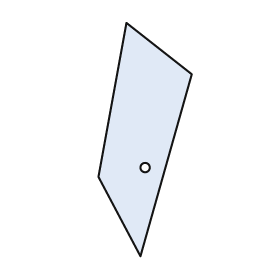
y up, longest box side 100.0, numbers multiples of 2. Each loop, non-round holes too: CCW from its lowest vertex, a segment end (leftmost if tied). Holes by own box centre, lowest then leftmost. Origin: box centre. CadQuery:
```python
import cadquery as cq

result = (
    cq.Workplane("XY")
    .moveTo(-2.0, -50.0)
    .lineTo(20.0, 28.0)
    .lineTo(-8.0, 50.0)
    .lineTo(-20.0, -16.0)
    .close()
    .moveTo(0.0, -12.0)
    .circle(2.0)
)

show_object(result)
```